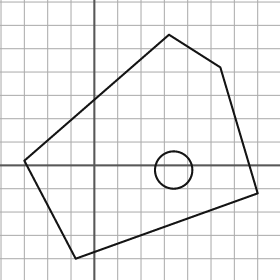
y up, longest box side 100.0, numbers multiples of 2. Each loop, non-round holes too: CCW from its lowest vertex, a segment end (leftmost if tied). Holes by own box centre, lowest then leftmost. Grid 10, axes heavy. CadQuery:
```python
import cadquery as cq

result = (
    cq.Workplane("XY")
    .moveTo(-8.0, -40.0)
    .lineTo(70.0, -12.0)
    .lineTo(54.0, 42.0)
    .lineTo(32.0, 56.0)
    .lineTo(-30.0, 2.0)
    .close()
    .moveTo(34.0, -2.0)
    .circle(8.0)
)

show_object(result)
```